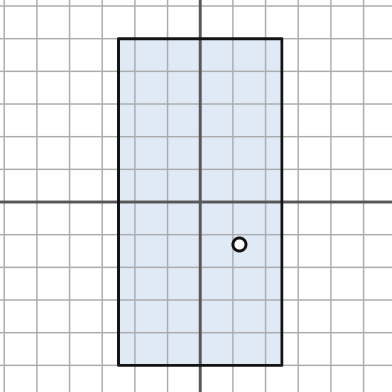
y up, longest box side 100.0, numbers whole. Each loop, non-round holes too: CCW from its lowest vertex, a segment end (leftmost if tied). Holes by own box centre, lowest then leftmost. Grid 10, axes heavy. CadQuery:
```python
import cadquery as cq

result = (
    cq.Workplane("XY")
    .moveTo(-25.0, -50.0)
    .lineTo(25.0, -50.0)
    .lineTo(25.0, 50.0)
    .lineTo(-25.0, 50.0)
    .close()
    .moveTo(12.0, -13.0)
    .circle(2.0)
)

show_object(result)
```